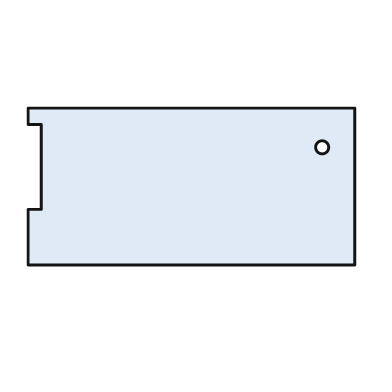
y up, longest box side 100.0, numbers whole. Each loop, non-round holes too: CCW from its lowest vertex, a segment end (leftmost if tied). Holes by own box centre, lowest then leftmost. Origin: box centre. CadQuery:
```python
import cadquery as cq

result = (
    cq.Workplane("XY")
    .moveTo(-50.0, -24.0)
    .lineTo(50.0, -24.0)
    .lineTo(50.0, 24.0)
    .lineTo(-50.0, 24.0)
    .lineTo(-50.0, 19.0)
    .lineTo(-46.0, 19.0)
    .lineTo(-46.0, -7.0)
    .lineTo(-50.0, -7.0)
    .close()
    .moveTo(40.0, 12.0)
    .circle(2.0)
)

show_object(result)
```